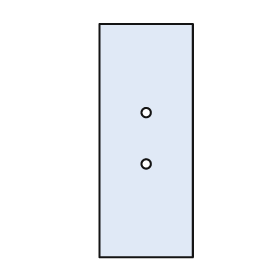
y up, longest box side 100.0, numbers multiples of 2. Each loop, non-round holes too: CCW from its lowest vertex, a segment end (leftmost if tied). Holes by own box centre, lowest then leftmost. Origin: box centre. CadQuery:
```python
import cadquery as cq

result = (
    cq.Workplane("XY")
    .moveTo(-20.0, -50.0)
    .lineTo(20.0, -50.0)
    .lineTo(20.0, 50.0)
    .lineTo(-20.0, 50.0)
    .close()
    .moveTo(0.0, -10.0)
    .circle(2.0)
    .moveTo(0.0, 12.0)
    .circle(2.0)
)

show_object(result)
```